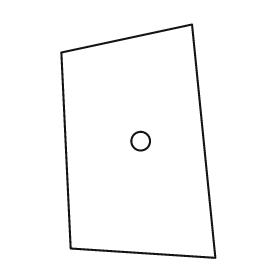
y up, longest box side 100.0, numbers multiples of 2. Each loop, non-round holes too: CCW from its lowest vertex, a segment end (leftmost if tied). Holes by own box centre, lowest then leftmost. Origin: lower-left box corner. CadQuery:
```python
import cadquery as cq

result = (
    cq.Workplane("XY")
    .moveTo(66.0, 0.0)
    .lineTo(56.0, 100.0)
    .lineTo(0.0, 88.0)
    .lineTo(4.0, 4.0)
    .close()
    .moveTo(34.0, 50.0)
    .circle(4.0)
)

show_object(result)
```